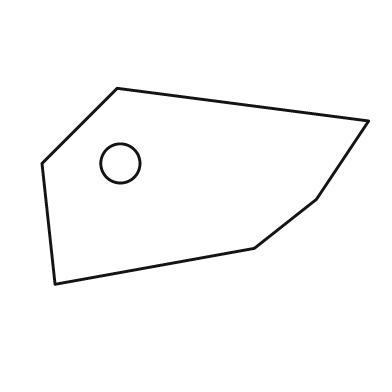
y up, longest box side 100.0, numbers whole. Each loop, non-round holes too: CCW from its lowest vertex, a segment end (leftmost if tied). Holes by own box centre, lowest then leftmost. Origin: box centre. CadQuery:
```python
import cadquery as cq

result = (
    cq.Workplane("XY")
    .moveTo(-46.0, -30.0)
    .lineTo(15.0, -19.0)
    .lineTo(34.0, -4.0)
    .lineTo(50.0, 20.0)
    .lineTo(-27.0, 30.0)
    .lineTo(-50.0, 7.0)
    .close()
    .moveTo(-26.0, 7.0)
    .circle(6.0)
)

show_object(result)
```